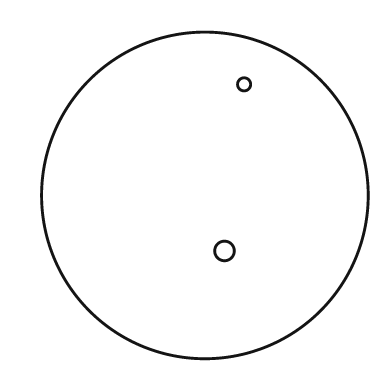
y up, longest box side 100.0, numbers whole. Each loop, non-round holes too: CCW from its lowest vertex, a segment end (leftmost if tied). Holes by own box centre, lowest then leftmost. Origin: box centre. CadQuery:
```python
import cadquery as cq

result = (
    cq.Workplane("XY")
    .moveTo(0.0, 0.0)
    .circle(50.0)
    .moveTo(6.0, -17.0)
    .circle(3.0)
    .moveTo(12.0, 34.0)
    .circle(2.0)
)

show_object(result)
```